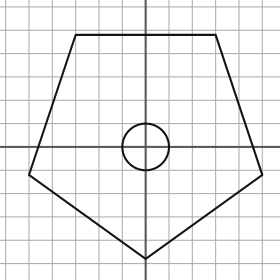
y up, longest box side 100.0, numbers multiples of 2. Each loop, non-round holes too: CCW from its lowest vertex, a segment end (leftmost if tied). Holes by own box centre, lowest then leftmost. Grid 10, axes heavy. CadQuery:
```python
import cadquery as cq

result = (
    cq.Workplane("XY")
    .moveTo(0.0, -48.0)
    .lineTo(50.0, -12.0)
    .lineTo(30.0, 48.0)
    .lineTo(-30.0, 48.0)
    .lineTo(-50.0, -12.0)
    .close()
    .moveTo(0.0, 0.0)
    .circle(10.0)
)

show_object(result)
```